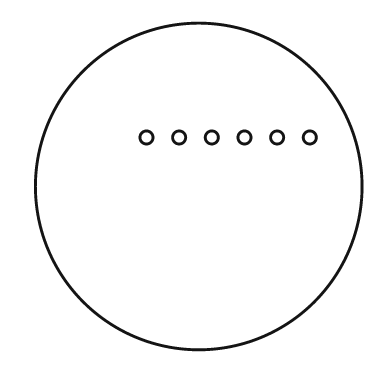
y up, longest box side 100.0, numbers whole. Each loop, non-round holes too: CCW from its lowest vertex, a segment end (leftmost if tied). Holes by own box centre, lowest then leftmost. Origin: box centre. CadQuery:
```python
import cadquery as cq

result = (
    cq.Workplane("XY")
    .moveTo(0.0, 0.0)
    .circle(50.0)
    .moveTo(-16.0, 15.0)
    .circle(2.0)
    .moveTo(-6.0, 15.0)
    .circle(2.0)
    .moveTo(4.0, 15.0)
    .circle(2.0)
    .moveTo(14.0, 15.0)
    .circle(2.0)
    .moveTo(24.0, 15.0)
    .circle(2.0)
    .moveTo(34.0, 15.0)
    .circle(2.0)
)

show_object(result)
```